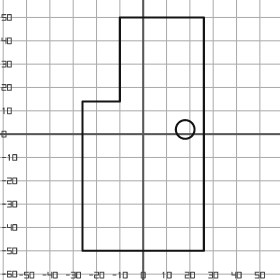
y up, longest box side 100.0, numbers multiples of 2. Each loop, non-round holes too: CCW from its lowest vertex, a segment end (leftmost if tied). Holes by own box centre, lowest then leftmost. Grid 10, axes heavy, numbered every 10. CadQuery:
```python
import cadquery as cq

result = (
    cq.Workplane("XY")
    .moveTo(-26.0, -50.0)
    .lineTo(26.0, -50.0)
    .lineTo(26.0, 50.0)
    .lineTo(-10.0, 50.0)
    .lineTo(-10.0, 14.0)
    .lineTo(-26.0, 14.0)
    .close()
    .moveTo(18.0, 2.0)
    .circle(4.0)
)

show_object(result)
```